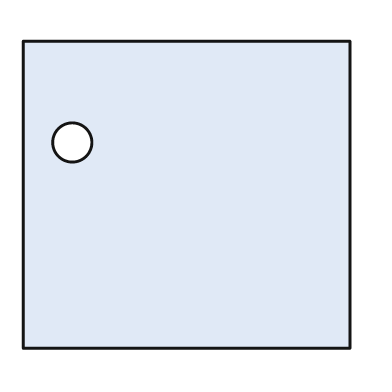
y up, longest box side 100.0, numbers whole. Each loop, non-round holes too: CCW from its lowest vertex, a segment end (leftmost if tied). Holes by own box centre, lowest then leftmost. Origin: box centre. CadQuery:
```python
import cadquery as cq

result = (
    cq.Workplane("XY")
    .moveTo(-50.0, -47.0)
    .lineTo(50.0, -47.0)
    .lineTo(50.0, 47.0)
    .lineTo(-50.0, 47.0)
    .close()
    .moveTo(-35.0, 16.0)
    .circle(6.0)
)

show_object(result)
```